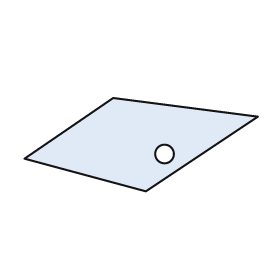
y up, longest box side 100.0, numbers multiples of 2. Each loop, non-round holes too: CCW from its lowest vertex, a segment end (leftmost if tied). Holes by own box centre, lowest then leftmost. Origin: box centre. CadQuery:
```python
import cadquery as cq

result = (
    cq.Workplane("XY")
    .moveTo(2.0, -20.0)
    .lineTo(50.0, 12.0)
    .lineTo(-12.0, 20.0)
    .lineTo(-50.0, -6.0)
    .close()
    .moveTo(10.0, -4.0)
    .circle(4.0)
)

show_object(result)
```